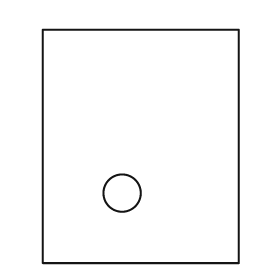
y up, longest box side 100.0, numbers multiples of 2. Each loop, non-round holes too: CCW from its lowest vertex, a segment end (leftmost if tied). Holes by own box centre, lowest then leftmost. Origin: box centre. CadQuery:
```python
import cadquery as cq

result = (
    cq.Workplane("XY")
    .moveTo(-42.0, -50.0)
    .lineTo(42.0, -50.0)
    .lineTo(42.0, 50.0)
    .lineTo(-42.0, 50.0)
    .close()
    .moveTo(-8.0, -20.0)
    .circle(8.0)
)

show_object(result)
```